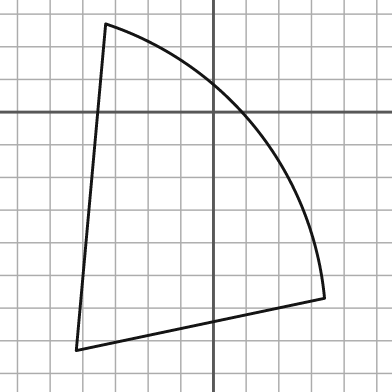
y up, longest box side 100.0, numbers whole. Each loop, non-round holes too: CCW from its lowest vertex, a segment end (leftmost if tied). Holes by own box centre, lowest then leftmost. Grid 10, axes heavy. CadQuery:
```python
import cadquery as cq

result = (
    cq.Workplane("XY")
    .moveTo(-42.0, -73.0)
    .lineTo(34.0, -57.0)
    .threePointArc((13.0, -5.0), (-33.0, 27.0))
    .close()
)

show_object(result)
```